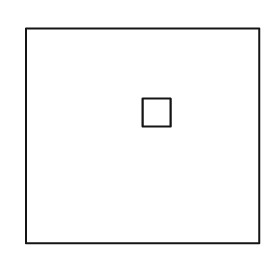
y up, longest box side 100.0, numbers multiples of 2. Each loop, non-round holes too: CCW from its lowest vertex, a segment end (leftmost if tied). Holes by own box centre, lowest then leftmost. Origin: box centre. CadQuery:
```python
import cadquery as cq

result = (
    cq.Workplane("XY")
    .moveTo(-50.0, -46.0)
    .lineTo(50.0, -46.0)
    .lineTo(50.0, 46.0)
    .lineTo(-50.0, 46.0)
    .close()
    .moveTo(0.0, 4.0)
    .lineTo(12.0, 4.0)
    .lineTo(12.0, 16.0)
    .lineTo(0.0, 16.0)
    .close()
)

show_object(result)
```